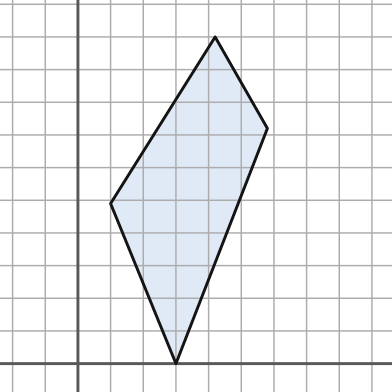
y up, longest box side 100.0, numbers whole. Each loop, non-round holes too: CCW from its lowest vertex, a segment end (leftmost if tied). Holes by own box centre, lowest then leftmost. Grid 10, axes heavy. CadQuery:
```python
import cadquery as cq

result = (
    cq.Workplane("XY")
    .moveTo(30.0, 0.0)
    .lineTo(58.0, 72.0)
    .lineTo(42.0, 100.0)
    .lineTo(10.0, 49.0)
    .close()
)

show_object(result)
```